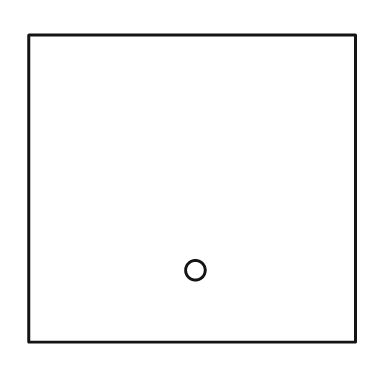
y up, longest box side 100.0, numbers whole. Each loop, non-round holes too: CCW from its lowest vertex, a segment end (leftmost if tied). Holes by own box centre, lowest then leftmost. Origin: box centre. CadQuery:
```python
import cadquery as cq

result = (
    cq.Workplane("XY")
    .moveTo(-50.0, -47.0)
    .lineTo(50.0, -47.0)
    .lineTo(50.0, 47.0)
    .lineTo(-50.0, 47.0)
    .close()
    .moveTo(1.0, -25.0)
    .circle(3.0)
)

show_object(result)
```